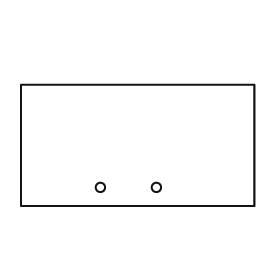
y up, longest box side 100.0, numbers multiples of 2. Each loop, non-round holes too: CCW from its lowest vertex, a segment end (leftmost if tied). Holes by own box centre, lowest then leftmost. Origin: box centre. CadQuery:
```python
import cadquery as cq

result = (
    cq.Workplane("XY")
    .moveTo(-50.0, -26.0)
    .lineTo(50.0, -26.0)
    .lineTo(50.0, 26.0)
    .lineTo(-50.0, 26.0)
    .close()
    .moveTo(-16.0, -18.0)
    .circle(2.0)
    .moveTo(8.0, -18.0)
    .circle(2.0)
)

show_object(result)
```